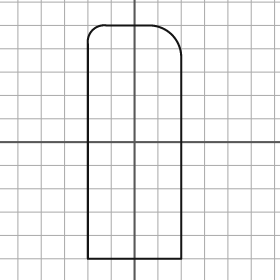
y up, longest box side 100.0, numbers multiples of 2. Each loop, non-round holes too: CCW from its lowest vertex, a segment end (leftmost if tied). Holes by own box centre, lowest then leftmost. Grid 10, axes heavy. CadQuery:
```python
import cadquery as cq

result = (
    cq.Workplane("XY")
    .moveTo(-20.0, -50.0)
    .lineTo(20.0, -50.0)
    .lineTo(20.0, 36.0)
    .threePointArc((16.0, 46.0), (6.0, 50.0))
    .lineTo(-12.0, 50.0)
    .threePointArc((-18.0, 48.0), (-20.0, 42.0))
    .close()
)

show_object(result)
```